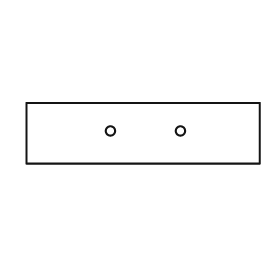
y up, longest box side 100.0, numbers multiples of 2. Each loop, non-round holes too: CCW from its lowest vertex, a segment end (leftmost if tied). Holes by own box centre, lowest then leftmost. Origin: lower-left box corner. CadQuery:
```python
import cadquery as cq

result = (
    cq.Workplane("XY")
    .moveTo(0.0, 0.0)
    .lineTo(100.0, 0.0)
    .lineTo(100.0, 26.0)
    .lineTo(0.0, 26.0)
    .close()
    .moveTo(36.0, 14.0)
    .circle(2.0)
    .moveTo(66.0, 14.0)
    .circle(2.0)
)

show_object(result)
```